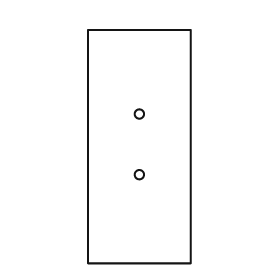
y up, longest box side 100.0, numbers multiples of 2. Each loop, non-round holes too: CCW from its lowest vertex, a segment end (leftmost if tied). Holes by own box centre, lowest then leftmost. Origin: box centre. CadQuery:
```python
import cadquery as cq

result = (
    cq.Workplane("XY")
    .moveTo(-22.0, -50.0)
    .lineTo(22.0, -50.0)
    .lineTo(22.0, 50.0)
    .lineTo(-22.0, 50.0)
    .close()
    .moveTo(0.0, -12.0)
    .circle(2.0)
    .moveTo(0.0, 14.0)
    .circle(2.0)
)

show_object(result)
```